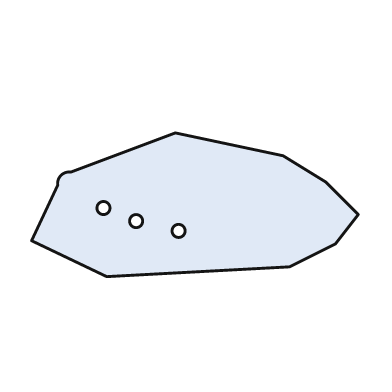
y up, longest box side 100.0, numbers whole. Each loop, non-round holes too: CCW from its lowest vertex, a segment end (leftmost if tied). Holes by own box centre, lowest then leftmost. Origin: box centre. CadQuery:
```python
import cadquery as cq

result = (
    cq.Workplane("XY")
    .moveTo(-27.0, -22.0)
    .lineTo(29.0, -19.0)
    .lineTo(43.0, -12.0)
    .lineTo(50.0, -3.0)
    .lineTo(40.0, 7.0)
    .lineTo(27.0, 15.0)
    .lineTo(-6.0, 22.0)
    .lineTo(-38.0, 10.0)
    .threePointArc((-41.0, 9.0), (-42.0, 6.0))
    .lineTo(-50.0, -11.0)
    .close()
    .moveTo(-5.0, -8.0)
    .circle(2.0)
    .moveTo(-18.0, -5.0)
    .circle(2.0)
    .moveTo(-28.0, -1.0)
    .circle(2.0)
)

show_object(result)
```